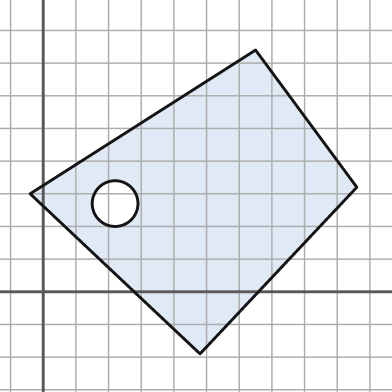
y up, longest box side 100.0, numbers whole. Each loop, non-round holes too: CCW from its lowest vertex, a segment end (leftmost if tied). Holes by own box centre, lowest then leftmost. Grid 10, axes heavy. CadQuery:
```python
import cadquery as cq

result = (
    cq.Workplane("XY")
    .moveTo(48.0, -19.0)
    .lineTo(96.0, 32.0)
    .lineTo(65.0, 74.0)
    .lineTo(-4.0, 30.0)
    .close()
    .moveTo(22.0, 27.0)
    .circle(7.0)
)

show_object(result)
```